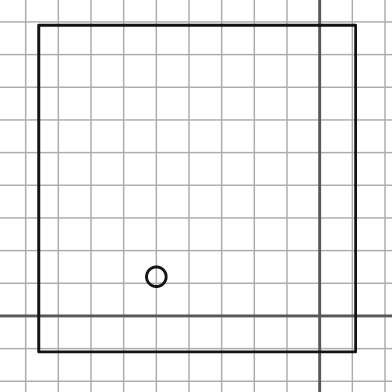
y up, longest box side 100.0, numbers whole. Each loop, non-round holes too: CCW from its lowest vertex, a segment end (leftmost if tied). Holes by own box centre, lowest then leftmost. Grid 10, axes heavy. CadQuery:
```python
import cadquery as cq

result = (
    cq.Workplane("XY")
    .moveTo(-86.0, -11.0)
    .lineTo(11.0, -11.0)
    .lineTo(11.0, 89.0)
    .lineTo(-86.0, 89.0)
    .close()
    .moveTo(-50.0, 12.0)
    .circle(3.0)
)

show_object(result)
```